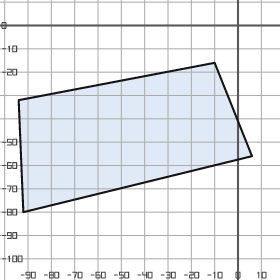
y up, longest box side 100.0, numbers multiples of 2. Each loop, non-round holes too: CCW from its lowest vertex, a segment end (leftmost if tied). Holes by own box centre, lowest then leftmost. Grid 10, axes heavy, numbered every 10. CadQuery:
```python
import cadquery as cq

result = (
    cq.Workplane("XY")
    .moveTo(-92.0, -80.0)
    .lineTo(6.0, -56.0)
    .lineTo(-10.0, -16.0)
    .lineTo(-94.0, -32.0)
    .close()
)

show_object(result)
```